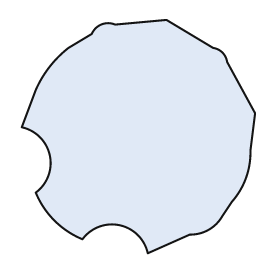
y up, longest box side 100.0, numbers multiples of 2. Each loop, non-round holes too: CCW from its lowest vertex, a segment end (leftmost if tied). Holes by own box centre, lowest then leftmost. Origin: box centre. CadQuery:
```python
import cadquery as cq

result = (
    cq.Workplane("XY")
    .moveTo(4.0, -50.0)
    .lineTo(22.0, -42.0)
    .threePointArc((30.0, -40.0), (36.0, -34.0))
    .lineTo(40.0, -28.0)
    .threePointArc((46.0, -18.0), (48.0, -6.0))
    .lineTo(50.0, 10.0)
    .lineTo(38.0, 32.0)
    .threePointArc((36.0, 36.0), (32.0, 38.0))
    .lineTo(12.0, 50.0)
    .lineTo(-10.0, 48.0)
    .threePointArc((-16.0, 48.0), (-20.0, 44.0))
    .lineTo(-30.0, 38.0)
    .threePointArc((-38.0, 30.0), (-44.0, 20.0))
    .lineTo(-50.0, 4.0)
    .threePointArc((-38.0, -8.0), (-44.0, -24.0))
    .threePointArc((-36.0, -36.0), (-24.0, -44.0))
    .threePointArc((-8.0, -38.0), (4.0, -50.0))
    .close()
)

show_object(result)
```